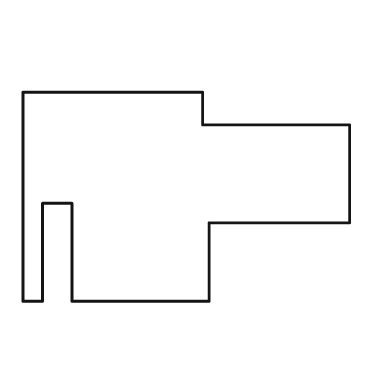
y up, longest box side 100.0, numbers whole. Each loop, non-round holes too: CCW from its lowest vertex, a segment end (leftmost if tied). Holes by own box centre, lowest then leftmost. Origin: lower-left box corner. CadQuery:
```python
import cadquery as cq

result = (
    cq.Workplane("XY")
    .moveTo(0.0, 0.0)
    .lineTo(6.0, 0.0)
    .lineTo(6.0, 30.0)
    .lineTo(15.0, 30.0)
    .lineTo(15.0, 0.0)
    .lineTo(57.0, 0.0)
    .lineTo(57.0, 24.0)
    .lineTo(100.0, 24.0)
    .lineTo(100.0, 54.0)
    .lineTo(55.0, 54.0)
    .lineTo(55.0, 64.0)
    .lineTo(0.0, 64.0)
    .close()
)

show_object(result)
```